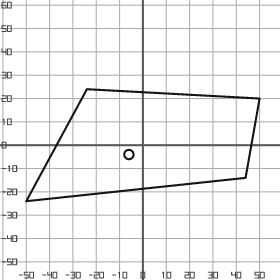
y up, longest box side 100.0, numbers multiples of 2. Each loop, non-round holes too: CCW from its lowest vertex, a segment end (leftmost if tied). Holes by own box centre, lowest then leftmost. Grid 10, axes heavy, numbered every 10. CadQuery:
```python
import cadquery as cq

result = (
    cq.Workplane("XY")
    .moveTo(-50.0, -24.0)
    .lineTo(44.0, -14.0)
    .lineTo(50.0, 20.0)
    .lineTo(-24.0, 24.0)
    .close()
    .moveTo(-6.0, -4.0)
    .circle(2.0)
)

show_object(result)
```